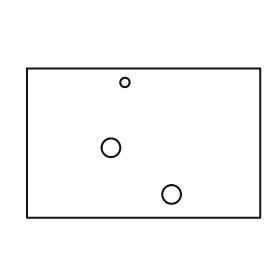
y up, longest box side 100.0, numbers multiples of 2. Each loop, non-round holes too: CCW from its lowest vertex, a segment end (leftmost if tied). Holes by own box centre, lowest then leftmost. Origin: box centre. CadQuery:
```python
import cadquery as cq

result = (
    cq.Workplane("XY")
    .moveTo(-50.0, -32.0)
    .lineTo(50.0, -32.0)
    .lineTo(50.0, 32.0)
    .lineTo(-50.0, 32.0)
    .close()
    .moveTo(12.0, -22.0)
    .circle(4.0)
    .moveTo(-14.0, -2.0)
    .circle(4.0)
    .moveTo(-8.0, 26.0)
    .circle(2.0)
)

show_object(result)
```